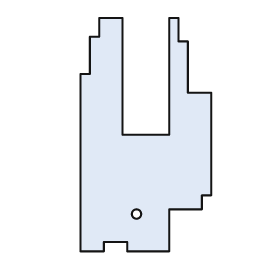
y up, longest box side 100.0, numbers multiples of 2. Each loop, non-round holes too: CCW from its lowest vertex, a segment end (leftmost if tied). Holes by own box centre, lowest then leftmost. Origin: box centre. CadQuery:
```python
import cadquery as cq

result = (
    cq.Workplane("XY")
    .moveTo(-28.0, -50.0)
    .lineTo(-18.0, -50.0)
    .lineTo(-18.0, -46.0)
    .lineTo(-8.0, -46.0)
    .lineTo(-8.0, -50.0)
    .lineTo(10.0, -50.0)
    .lineTo(10.0, -32.0)
    .lineTo(24.0, -32.0)
    .lineTo(24.0, -26.0)
    .lineTo(28.0, -26.0)
    .lineTo(28.0, 18.0)
    .lineTo(18.0, 18.0)
    .lineTo(18.0, 40.0)
    .lineTo(14.0, 40.0)
    .lineTo(14.0, 50.0)
    .lineTo(10.0, 50.0)
    .lineTo(10.0, 0.0)
    .lineTo(-10.0, 0.0)
    .lineTo(-10.0, 50.0)
    .lineTo(-20.0, 50.0)
    .lineTo(-20.0, 42.0)
    .lineTo(-24.0, 42.0)
    .lineTo(-24.0, 26.0)
    .lineTo(-28.0, 26.0)
    .close()
    .moveTo(-4.0, -34.0)
    .circle(2.0)
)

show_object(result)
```